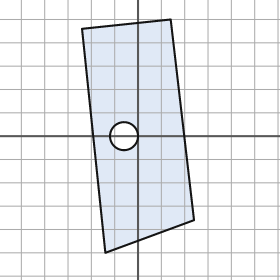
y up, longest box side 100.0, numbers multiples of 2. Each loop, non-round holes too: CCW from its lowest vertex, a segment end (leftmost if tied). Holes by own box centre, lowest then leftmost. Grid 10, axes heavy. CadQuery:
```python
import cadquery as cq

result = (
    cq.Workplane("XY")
    .moveTo(-14.0, -50.0)
    .lineTo(24.0, -36.0)
    .lineTo(14.0, 50.0)
    .lineTo(-24.0, 46.0)
    .close()
    .moveTo(-6.0, 0.0)
    .circle(6.0)
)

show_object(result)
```